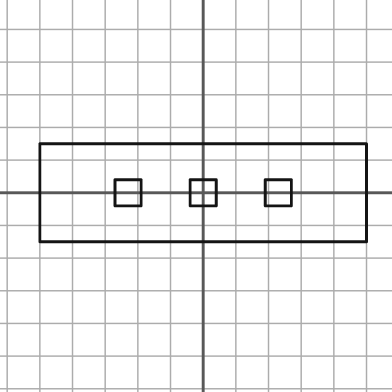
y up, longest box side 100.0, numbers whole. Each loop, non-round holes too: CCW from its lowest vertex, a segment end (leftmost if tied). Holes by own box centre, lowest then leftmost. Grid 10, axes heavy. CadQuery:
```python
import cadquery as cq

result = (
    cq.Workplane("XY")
    .moveTo(-50.0, -15.0)
    .lineTo(50.0, -15.0)
    .lineTo(50.0, 15.0)
    .lineTo(-50.0, 15.0)
    .close()
    .moveTo(-27.0, -4.0)
    .lineTo(-19.0, -4.0)
    .lineTo(-19.0, 4.0)
    .lineTo(-27.0, 4.0)
    .close()
    .moveTo(-4.0, -4.0)
    .lineTo(4.0, -4.0)
    .lineTo(4.0, 4.0)
    .lineTo(-4.0, 4.0)
    .close()
    .moveTo(19.0, -4.0)
    .lineTo(27.0, -4.0)
    .lineTo(27.0, 4.0)
    .lineTo(19.0, 4.0)
    .close()
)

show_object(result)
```